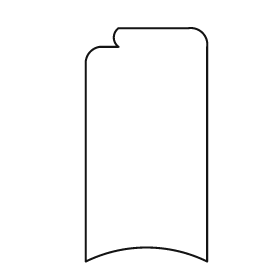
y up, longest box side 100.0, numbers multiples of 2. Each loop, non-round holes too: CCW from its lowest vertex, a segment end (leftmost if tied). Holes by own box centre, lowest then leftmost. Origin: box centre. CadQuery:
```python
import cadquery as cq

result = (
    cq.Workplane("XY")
    .moveTo(-26.0, -50.0)
    .threePointArc((0.0, -44.0), (26.0, -50.0))
    .lineTo(26.0, 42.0)
    .threePointArc((24.0, 48.0), (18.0, 50.0))
    .lineTo(-12.0, 50.0)
    .threePointArc((-14.0, 46.0), (-12.0, 42.0))
    .lineTo(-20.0, 42.0)
    .threePointArc((-24.0, 40.0), (-26.0, 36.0))
    .close()
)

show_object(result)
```